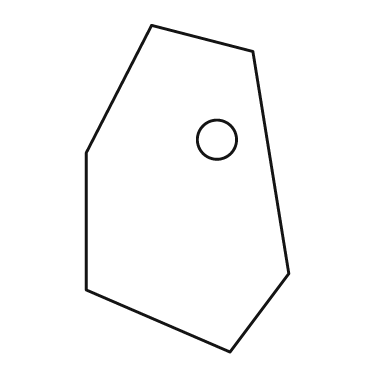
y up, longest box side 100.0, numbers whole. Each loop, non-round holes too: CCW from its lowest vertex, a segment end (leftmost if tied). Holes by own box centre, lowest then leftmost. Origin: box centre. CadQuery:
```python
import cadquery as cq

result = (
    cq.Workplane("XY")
    .moveTo(13.0, -50.0)
    .lineTo(31.0, -26.0)
    .lineTo(20.0, 42.0)
    .lineTo(-11.0, 50.0)
    .lineTo(-31.0, 11.0)
    .lineTo(-31.0, -31.0)
    .close()
    .moveTo(9.0, 15.0)
    .circle(6.0)
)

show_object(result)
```